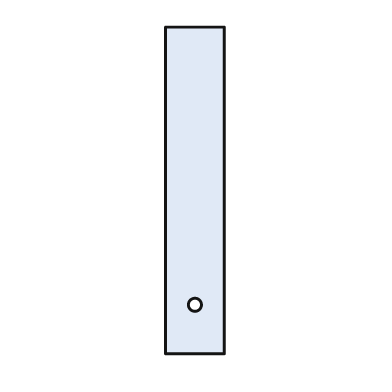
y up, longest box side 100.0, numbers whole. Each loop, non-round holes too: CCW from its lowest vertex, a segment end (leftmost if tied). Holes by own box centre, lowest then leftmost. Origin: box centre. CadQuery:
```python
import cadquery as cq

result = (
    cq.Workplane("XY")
    .moveTo(-9.0, -50.0)
    .lineTo(9.0, -50.0)
    .lineTo(9.0, 50.0)
    .lineTo(-9.0, 50.0)
    .close()
    .moveTo(0.0, -35.0)
    .circle(2.0)
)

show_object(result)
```